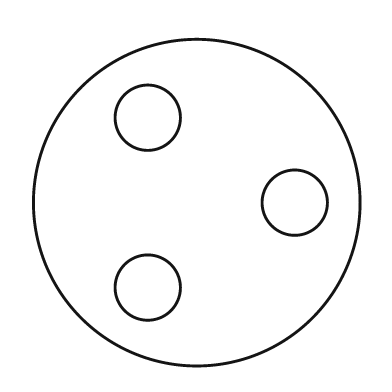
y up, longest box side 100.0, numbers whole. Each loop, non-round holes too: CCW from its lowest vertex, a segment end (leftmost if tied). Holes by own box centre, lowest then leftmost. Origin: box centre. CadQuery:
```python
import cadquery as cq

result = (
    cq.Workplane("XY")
    .moveTo(0.0, 0.0)
    .circle(50.0)
    .moveTo(-15.0, -26.0)
    .circle(10.0)
    .moveTo(30.0, 0.0)
    .circle(10.0)
    .moveTo(-15.0, 26.0)
    .circle(10.0)
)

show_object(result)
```